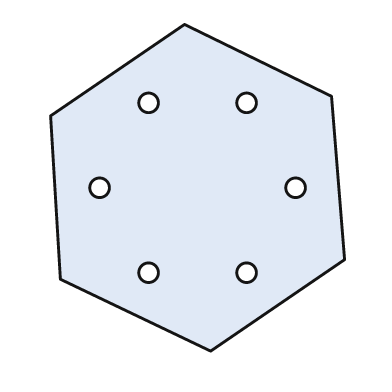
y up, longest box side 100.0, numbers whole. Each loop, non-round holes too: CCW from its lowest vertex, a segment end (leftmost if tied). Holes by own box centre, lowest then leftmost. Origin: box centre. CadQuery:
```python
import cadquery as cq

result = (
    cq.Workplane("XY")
    .moveTo(4.0, -50.0)
    .lineTo(45.0, -22.0)
    .lineTo(41.0, 28.0)
    .lineTo(-4.0, 50.0)
    .lineTo(-45.0, 22.0)
    .lineTo(-42.0, -28.0)
    .close()
    .moveTo(-15.0, -26.0)
    .circle(3.0)
    .moveTo(15.0, -26.0)
    .circle(3.0)
    .moveTo(-30.0, 0.0)
    .circle(3.0)
    .moveTo(30.0, 0.0)
    .circle(3.0)
    .moveTo(-15.0, 26.0)
    .circle(3.0)
    .moveTo(15.0, 26.0)
    .circle(3.0)
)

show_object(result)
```